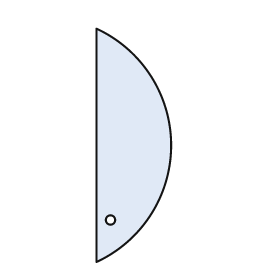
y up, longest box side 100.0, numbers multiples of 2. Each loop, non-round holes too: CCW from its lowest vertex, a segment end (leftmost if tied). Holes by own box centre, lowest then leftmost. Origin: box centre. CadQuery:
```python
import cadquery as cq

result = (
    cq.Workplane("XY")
    .moveTo(-16.0, -50.0)
    .threePointArc((16.0, 0.0), (-16.0, 50.0))
    .close()
    .moveTo(-10.0, -32.0)
    .circle(2.0)
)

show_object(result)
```